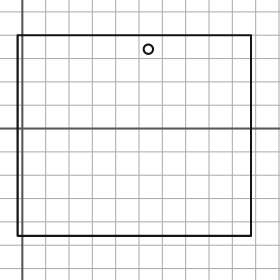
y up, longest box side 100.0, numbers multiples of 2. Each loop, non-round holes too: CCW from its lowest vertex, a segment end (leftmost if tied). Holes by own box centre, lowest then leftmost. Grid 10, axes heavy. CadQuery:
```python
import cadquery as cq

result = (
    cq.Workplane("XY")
    .moveTo(-2.0, -46.0)
    .lineTo(98.0, -46.0)
    .lineTo(98.0, 40.0)
    .lineTo(-2.0, 40.0)
    .close()
    .moveTo(54.0, 34.0)
    .circle(2.0)
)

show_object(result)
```